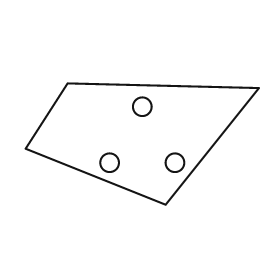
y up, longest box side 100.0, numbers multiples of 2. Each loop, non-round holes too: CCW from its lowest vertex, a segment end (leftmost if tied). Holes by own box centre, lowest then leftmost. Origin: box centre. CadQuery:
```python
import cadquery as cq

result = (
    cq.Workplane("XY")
    .moveTo(10.0, -26.0)
    .lineTo(50.0, 24.0)
    .lineTo(-32.0, 26.0)
    .lineTo(-50.0, -2.0)
    .close()
    .moveTo(-14.0, -8.0)
    .circle(4.0)
    .moveTo(14.0, -8.0)
    .circle(4.0)
    .moveTo(0.0, 16.0)
    .circle(4.0)
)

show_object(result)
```